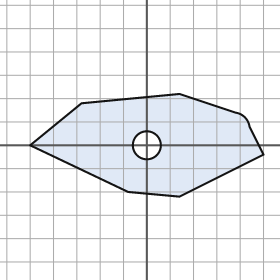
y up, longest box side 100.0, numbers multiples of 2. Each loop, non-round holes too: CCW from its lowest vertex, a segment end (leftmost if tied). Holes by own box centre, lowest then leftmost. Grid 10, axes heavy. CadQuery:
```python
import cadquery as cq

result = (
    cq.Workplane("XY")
    .moveTo(14.0, -22.0)
    .lineTo(50.0, -4.0)
    .lineTo(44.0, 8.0)
    .threePointArc((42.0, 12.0), (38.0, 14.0))
    .lineTo(14.0, 22.0)
    .lineTo(-28.0, 18.0)
    .lineTo(-50.0, 0.0)
    .lineTo(-8.0, -20.0)
    .close()
    .moveTo(0.0, 0.0)
    .circle(6.0)
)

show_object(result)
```